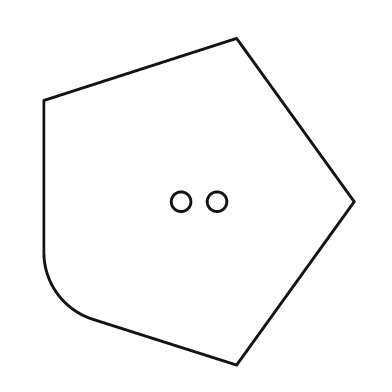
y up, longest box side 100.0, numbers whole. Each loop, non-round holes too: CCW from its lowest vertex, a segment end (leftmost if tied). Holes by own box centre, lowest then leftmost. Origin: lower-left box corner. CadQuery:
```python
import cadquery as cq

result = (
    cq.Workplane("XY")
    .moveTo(59.0, 0.0)
    .lineTo(95.0, 50.0)
    .lineTo(59.0, 100.0)
    .lineTo(0.0, 81.0)
    .lineTo(0.0, 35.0)
    .threePointArc((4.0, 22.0), (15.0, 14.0))
    .close()
    .moveTo(42.0, 50.0)
    .circle(3.0)
    .moveTo(53.0, 50.0)
    .circle(3.0)
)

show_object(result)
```